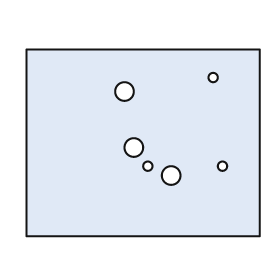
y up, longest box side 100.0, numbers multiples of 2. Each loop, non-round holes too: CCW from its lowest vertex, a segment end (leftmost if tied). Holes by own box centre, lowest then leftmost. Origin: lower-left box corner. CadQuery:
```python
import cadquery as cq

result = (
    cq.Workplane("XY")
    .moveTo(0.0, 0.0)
    .lineTo(100.0, 0.0)
    .lineTo(100.0, 80.0)
    .lineTo(0.0, 80.0)
    .close()
    .moveTo(62.0, 26.0)
    .circle(4.0)
    .moveTo(52.0, 30.0)
    .circle(2.0)
    .moveTo(84.0, 30.0)
    .circle(2.0)
    .moveTo(46.0, 38.0)
    .circle(4.0)
    .moveTo(42.0, 62.0)
    .circle(4.0)
    .moveTo(80.0, 68.0)
    .circle(2.0)
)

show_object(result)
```